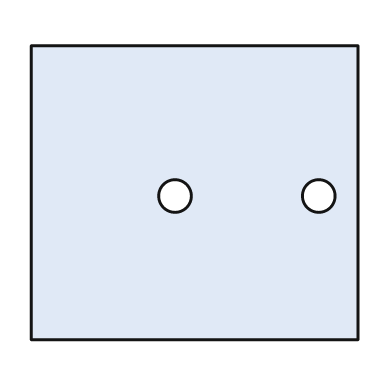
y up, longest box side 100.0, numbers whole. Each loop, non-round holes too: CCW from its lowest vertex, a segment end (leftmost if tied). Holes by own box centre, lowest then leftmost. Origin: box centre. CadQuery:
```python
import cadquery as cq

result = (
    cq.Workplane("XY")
    .moveTo(-50.0, -45.0)
    .lineTo(50.0, -45.0)
    .lineTo(50.0, 45.0)
    .lineTo(-50.0, 45.0)
    .close()
    .moveTo(-6.0, -1.0)
    .circle(5.0)
    .moveTo(38.0, -1.0)
    .circle(5.0)
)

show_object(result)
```